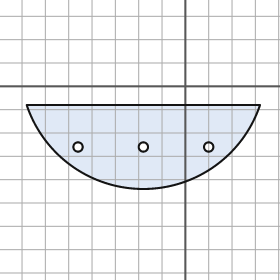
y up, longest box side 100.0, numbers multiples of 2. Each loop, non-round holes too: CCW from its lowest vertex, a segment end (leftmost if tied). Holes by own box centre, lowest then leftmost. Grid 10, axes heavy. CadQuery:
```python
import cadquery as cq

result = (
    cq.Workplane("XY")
    .moveTo(-68.0, -8.0)
    .threePointArc((-18.0, -44.0), (32.0, -8.0))
    .close()
    .moveTo(-46.0, -26.0)
    .circle(2.0)
    .moveTo(-18.0, -26.0)
    .circle(2.0)
    .moveTo(10.0, -26.0)
    .circle(2.0)
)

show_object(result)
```